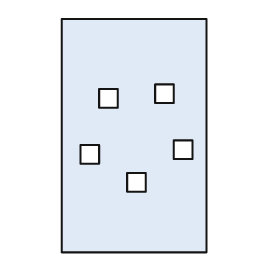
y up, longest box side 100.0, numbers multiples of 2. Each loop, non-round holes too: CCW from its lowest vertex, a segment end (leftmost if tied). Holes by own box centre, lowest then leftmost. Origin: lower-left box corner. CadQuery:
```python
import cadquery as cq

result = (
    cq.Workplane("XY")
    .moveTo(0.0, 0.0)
    .lineTo(62.0, 0.0)
    .lineTo(62.0, 100.0)
    .lineTo(0.0, 100.0)
    .close()
    .moveTo(28.0, 26.0)
    .lineTo(36.0, 26.0)
    .lineTo(36.0, 34.0)
    .lineTo(28.0, 34.0)
    .close()
    .moveTo(8.0, 38.0)
    .lineTo(16.0, 38.0)
    .lineTo(16.0, 46.0)
    .lineTo(8.0, 46.0)
    .close()
    .moveTo(48.0, 40.0)
    .lineTo(56.0, 40.0)
    .lineTo(56.0, 48.0)
    .lineTo(48.0, 48.0)
    .close()
    .moveTo(16.0, 62.0)
    .lineTo(24.0, 62.0)
    .lineTo(24.0, 70.0)
    .lineTo(16.0, 70.0)
    .close()
    .moveTo(40.0, 64.0)
    .lineTo(48.0, 64.0)
    .lineTo(48.0, 72.0)
    .lineTo(40.0, 72.0)
    .close()
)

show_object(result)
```